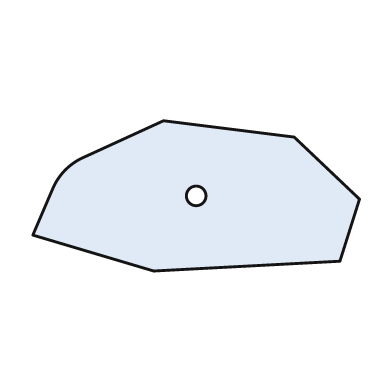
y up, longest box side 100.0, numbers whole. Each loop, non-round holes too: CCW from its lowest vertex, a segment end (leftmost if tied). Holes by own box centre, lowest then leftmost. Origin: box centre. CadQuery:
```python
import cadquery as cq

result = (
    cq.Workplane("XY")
    .moveTo(-13.0, -23.0)
    .lineTo(44.0, -20.0)
    .lineTo(50.0, -1.0)
    .lineTo(30.0, 18.0)
    .lineTo(-10.0, 23.0)
    .lineTo(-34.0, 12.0)
    .threePointArc((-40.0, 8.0), (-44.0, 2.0))
    .lineTo(-50.0, -12.0)
    .close()
    .moveTo(0.0, 0.0)
    .circle(3.0)
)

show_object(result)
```